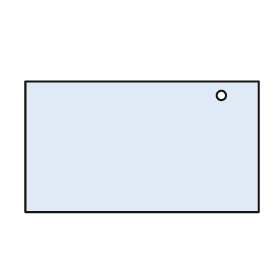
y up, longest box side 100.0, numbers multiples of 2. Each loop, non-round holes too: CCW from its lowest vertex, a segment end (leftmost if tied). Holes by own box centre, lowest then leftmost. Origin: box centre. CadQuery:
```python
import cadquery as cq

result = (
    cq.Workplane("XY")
    .moveTo(-50.0, -28.0)
    .lineTo(50.0, -28.0)
    .lineTo(50.0, 28.0)
    .lineTo(-50.0, 28.0)
    .close()
    .moveTo(34.0, 22.0)
    .circle(2.0)
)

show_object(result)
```